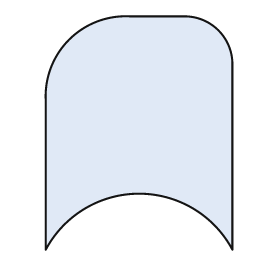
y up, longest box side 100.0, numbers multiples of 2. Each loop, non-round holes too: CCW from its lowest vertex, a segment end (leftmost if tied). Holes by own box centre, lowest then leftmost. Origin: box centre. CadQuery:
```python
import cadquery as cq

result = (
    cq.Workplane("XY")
    .moveTo(-40.0, -50.0)
    .threePointArc((0.0, -26.0), (40.0, -50.0))
    .lineTo(40.0, 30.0)
    .threePointArc((34.0, 44.0), (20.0, 50.0))
    .lineTo(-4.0, 50.0)
    .threePointArc((-30.0, 40.0), (-40.0, 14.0))
    .close()
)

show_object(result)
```